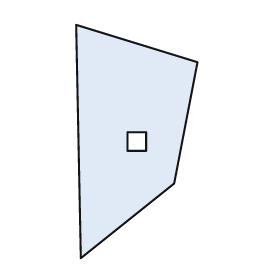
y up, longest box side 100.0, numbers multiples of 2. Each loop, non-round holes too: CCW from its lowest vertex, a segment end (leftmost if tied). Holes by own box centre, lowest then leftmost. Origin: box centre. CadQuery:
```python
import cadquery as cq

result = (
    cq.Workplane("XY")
    .moveTo(-24.0, -50.0)
    .lineTo(16.0, -18.0)
    .lineTo(26.0, 34.0)
    .lineTo(-26.0, 50.0)
    .close()
    .moveTo(-4.0, -4.0)
    .lineTo(4.0, -4.0)
    .lineTo(4.0, 4.0)
    .lineTo(-4.0, 4.0)
    .close()
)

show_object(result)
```